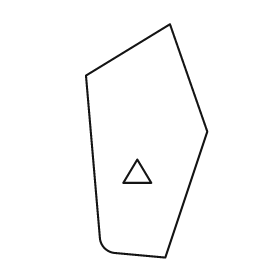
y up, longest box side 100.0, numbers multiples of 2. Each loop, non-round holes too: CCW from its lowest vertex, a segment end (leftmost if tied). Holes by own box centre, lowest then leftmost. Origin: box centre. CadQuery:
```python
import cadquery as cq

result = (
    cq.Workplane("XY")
    .moveTo(8.0, -50.0)
    .lineTo(26.0, 4.0)
    .lineTo(10.0, 50.0)
    .lineTo(-26.0, 28.0)
    .lineTo(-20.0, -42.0)
    .threePointArc((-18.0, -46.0), (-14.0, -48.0))
    .close()
    .moveTo(-10.0, -18.0)
    .lineTo(2.0, -18.0)
    .lineTo(-4.0, -8.0)
    .close()
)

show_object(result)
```